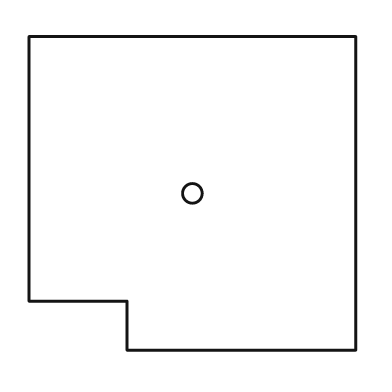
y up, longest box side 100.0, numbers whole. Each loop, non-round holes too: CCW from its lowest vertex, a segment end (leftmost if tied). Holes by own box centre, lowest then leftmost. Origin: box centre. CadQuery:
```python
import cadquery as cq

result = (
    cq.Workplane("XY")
    .moveTo(-20.0, -48.0)
    .lineTo(50.0, -48.0)
    .lineTo(50.0, 48.0)
    .lineTo(-50.0, 48.0)
    .lineTo(-50.0, -33.0)
    .lineTo(-20.0, -33.0)
    .close()
    .moveTo(0.0, 0.0)
    .circle(3.0)
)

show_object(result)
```